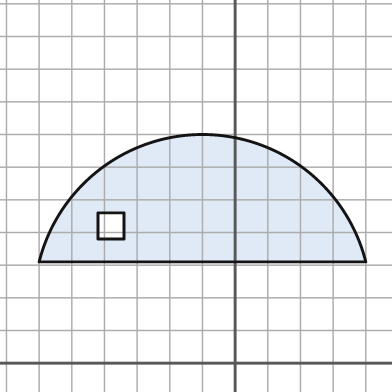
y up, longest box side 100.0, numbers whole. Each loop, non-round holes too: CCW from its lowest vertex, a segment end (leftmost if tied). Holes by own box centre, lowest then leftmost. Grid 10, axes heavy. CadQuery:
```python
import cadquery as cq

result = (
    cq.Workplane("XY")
    .moveTo(-60.0, 31.0)
    .lineTo(40.0, 31.0)
    .threePointArc((-10.0, 70.0), (-60.0, 31.0))
    .close()
    .moveTo(-42.0, 38.0)
    .lineTo(-34.0, 38.0)
    .lineTo(-34.0, 46.0)
    .lineTo(-42.0, 46.0)
    .close()
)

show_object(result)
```